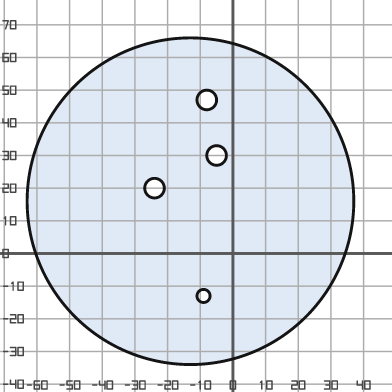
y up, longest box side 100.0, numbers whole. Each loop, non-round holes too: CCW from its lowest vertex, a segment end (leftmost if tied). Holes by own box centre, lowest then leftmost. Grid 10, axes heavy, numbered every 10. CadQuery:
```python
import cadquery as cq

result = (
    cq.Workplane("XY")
    .moveTo(-13.0, 16.0)
    .circle(50.0)
    .moveTo(-9.0, -13.0)
    .circle(2.0)
    .moveTo(-24.0, 20.0)
    .circle(3.0)
    .moveTo(-5.0, 30.0)
    .circle(3.0)
    .moveTo(-8.0, 47.0)
    .circle(3.0)
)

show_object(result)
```